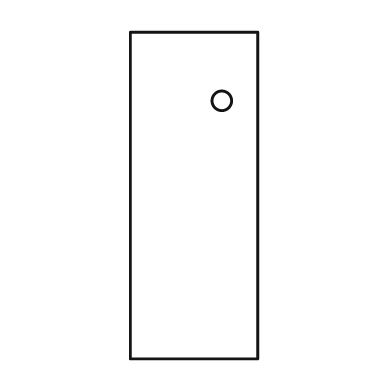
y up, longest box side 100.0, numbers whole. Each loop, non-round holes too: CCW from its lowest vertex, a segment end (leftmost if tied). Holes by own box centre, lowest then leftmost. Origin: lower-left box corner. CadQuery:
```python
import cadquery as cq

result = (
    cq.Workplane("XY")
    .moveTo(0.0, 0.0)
    .lineTo(39.0, 0.0)
    .lineTo(39.0, 100.0)
    .lineTo(0.0, 100.0)
    .close()
    .moveTo(28.0, 79.0)
    .circle(3.0)
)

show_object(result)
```